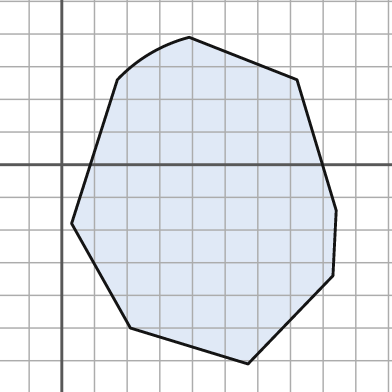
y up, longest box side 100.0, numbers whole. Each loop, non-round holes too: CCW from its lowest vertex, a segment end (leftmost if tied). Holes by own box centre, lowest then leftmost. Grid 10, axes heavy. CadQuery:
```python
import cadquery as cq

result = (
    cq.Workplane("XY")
    .moveTo(57.0, -61.0)
    .lineTo(83.0, -34.0)
    .lineTo(84.0, -14.0)
    .lineTo(72.0, 26.0)
    .lineTo(39.0, 39.0)
    .threePointArc((27.0, 34.0), (17.0, 26.0))
    .lineTo(3.0, -18.0)
    .lineTo(21.0, -50.0)
    .close()
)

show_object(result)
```